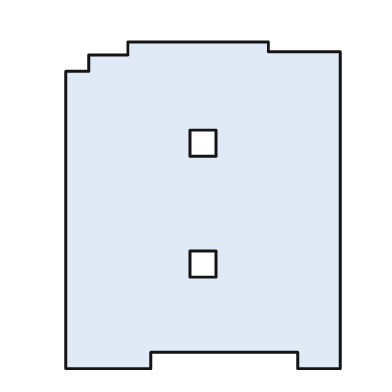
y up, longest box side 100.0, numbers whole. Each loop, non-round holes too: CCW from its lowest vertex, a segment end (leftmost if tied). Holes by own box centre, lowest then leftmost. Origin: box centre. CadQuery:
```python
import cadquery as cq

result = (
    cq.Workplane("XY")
    .moveTo(-42.0, -50.0)
    .lineTo(-16.0, -50.0)
    .lineTo(-16.0, -45.0)
    .lineTo(29.0, -45.0)
    .lineTo(29.0, -50.0)
    .lineTo(42.0, -50.0)
    .lineTo(42.0, 47.0)
    .lineTo(20.0, 47.0)
    .lineTo(20.0, 50.0)
    .lineTo(-23.0, 50.0)
    .lineTo(-23.0, 46.0)
    .lineTo(-35.0, 46.0)
    .lineTo(-35.0, 41.0)
    .lineTo(-42.0, 41.0)
    .close()
    .moveTo(-4.0, -22.0)
    .lineTo(4.0, -22.0)
    .lineTo(4.0, -14.0)
    .lineTo(-4.0, -14.0)
    .close()
    .moveTo(-4.0, 15.0)
    .lineTo(4.0, 15.0)
    .lineTo(4.0, 23.0)
    .lineTo(-4.0, 23.0)
    .close()
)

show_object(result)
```